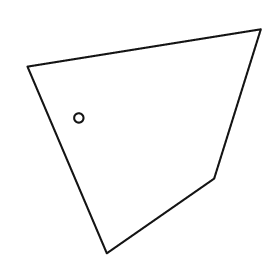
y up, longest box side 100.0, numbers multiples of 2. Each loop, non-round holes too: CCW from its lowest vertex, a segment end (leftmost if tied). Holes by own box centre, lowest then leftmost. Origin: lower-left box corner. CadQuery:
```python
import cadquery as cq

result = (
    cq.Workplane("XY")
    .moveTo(34.0, 0.0)
    .lineTo(80.0, 32.0)
    .lineTo(100.0, 96.0)
    .lineTo(0.0, 80.0)
    .close()
    .moveTo(22.0, 58.0)
    .circle(2.0)
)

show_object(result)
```